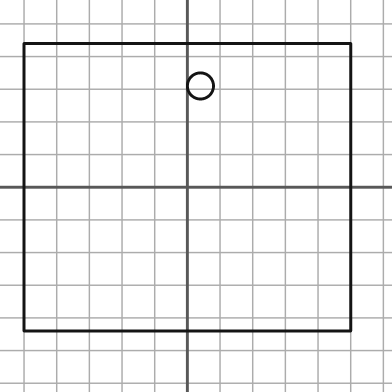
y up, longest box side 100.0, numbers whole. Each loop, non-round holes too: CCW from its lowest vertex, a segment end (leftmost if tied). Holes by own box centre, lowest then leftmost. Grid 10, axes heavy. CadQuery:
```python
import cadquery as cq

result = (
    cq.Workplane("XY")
    .moveTo(-50.0, -44.0)
    .lineTo(50.0, -44.0)
    .lineTo(50.0, 44.0)
    .lineTo(-50.0, 44.0)
    .close()
    .moveTo(4.0, 31.0)
    .circle(4.0)
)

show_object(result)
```